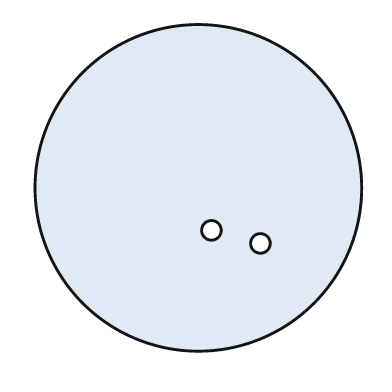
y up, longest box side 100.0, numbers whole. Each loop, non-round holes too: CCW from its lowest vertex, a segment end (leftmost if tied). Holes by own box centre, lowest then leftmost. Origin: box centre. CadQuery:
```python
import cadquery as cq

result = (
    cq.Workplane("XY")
    .moveTo(0.0, 0.0)
    .circle(50.0)
    .moveTo(19.0, -17.0)
    .circle(3.0)
    .moveTo(4.0, -13.0)
    .circle(3.0)
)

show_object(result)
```